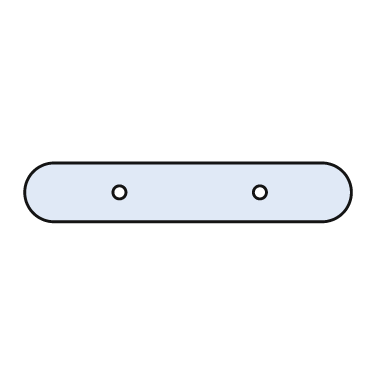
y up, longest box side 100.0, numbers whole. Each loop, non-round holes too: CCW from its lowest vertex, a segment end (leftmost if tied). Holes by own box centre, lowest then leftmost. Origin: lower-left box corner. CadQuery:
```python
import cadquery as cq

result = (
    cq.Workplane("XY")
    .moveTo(9.0, 0.0)
    .lineTo(91.0, 0.0)
    .threePointArc((100.0, 9.0), (91.0, 18.0))
    .lineTo(9.0, 18.0)
    .threePointArc((0.0, 9.0), (9.0, 0.0))
    .close()
    .moveTo(29.0, 9.0)
    .circle(2.0)
    .moveTo(72.0, 9.0)
    .circle(2.0)
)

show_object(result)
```